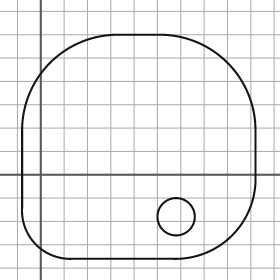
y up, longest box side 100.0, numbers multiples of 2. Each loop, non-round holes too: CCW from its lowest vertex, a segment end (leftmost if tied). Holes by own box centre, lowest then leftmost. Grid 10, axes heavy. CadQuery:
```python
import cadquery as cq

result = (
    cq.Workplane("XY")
    .moveTo(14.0, -36.0)
    .lineTo(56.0, -36.0)
    .threePointArc((82.0, -26.0), (92.0, 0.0))
    .lineTo(92.0, 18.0)
    .threePointArc((80.0, 48.0), (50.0, 60.0))
    .lineTo(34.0, 60.0)
    .threePointArc((4.0, 48.0), (-8.0, 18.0))
    .lineTo(-8.0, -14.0)
    .threePointArc((-2.0, -30.0), (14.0, -36.0))
    .close()
    .moveTo(58.0, -18.0)
    .circle(8.0)
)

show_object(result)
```